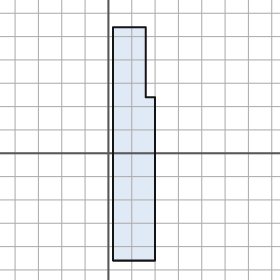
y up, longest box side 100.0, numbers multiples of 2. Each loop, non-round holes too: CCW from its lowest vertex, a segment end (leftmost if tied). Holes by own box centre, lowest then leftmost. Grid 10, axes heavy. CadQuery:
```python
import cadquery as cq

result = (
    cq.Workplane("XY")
    .moveTo(2.0, -46.0)
    .lineTo(20.0, -46.0)
    .lineTo(20.0, 24.0)
    .lineTo(16.0, 24.0)
    .lineTo(16.0, 54.0)
    .lineTo(2.0, 54.0)
    .close()
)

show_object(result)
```